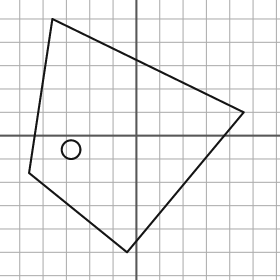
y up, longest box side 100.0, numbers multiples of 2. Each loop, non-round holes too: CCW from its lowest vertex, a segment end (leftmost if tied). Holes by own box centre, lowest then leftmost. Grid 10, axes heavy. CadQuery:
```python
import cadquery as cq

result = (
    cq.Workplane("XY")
    .moveTo(-4.0, -50.0)
    .lineTo(46.0, 10.0)
    .lineTo(-36.0, 50.0)
    .lineTo(-46.0, -16.0)
    .close()
    .moveTo(-28.0, -6.0)
    .circle(4.0)
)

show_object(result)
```